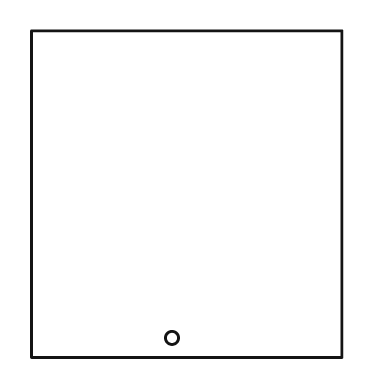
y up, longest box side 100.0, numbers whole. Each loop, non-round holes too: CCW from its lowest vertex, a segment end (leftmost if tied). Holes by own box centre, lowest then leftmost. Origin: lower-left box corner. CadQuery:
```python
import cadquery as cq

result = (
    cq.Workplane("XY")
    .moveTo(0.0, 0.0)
    .lineTo(95.0, 0.0)
    .lineTo(95.0, 100.0)
    .lineTo(0.0, 100.0)
    .close()
    .moveTo(43.0, 6.0)
    .circle(2.0)
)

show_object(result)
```